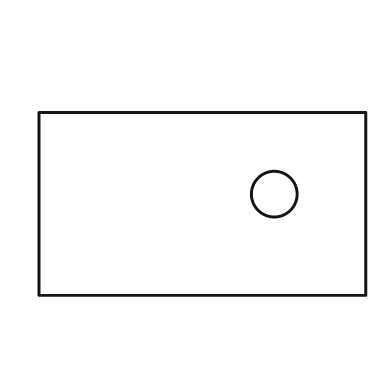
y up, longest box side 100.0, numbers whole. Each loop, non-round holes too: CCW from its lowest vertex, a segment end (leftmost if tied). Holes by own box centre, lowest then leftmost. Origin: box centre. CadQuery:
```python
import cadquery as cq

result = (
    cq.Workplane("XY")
    .moveTo(-50.0, -28.0)
    .lineTo(50.0, -28.0)
    .lineTo(50.0, 28.0)
    .lineTo(-50.0, 28.0)
    .close()
    .moveTo(22.0, 3.0)
    .circle(7.0)
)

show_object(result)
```